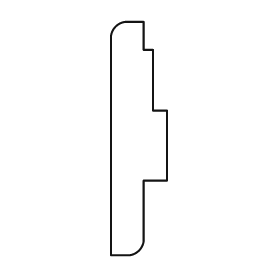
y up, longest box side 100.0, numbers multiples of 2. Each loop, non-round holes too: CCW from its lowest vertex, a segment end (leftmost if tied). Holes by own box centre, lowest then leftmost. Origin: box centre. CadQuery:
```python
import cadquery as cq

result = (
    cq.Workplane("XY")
    .moveTo(-12.0, -50.0)
    .lineTo(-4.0, -50.0)
    .threePointArc((0.0, -48.0), (2.0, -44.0))
    .lineTo(2.0, -18.0)
    .lineTo(12.0, -18.0)
    .lineTo(12.0, 12.0)
    .lineTo(6.0, 12.0)
    .lineTo(6.0, 38.0)
    .lineTo(2.0, 38.0)
    .lineTo(2.0, 50.0)
    .lineTo(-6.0, 50.0)
    .threePointArc((-10.0, 48.0), (-12.0, 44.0))
    .close()
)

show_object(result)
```